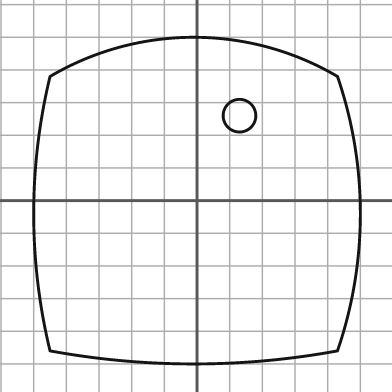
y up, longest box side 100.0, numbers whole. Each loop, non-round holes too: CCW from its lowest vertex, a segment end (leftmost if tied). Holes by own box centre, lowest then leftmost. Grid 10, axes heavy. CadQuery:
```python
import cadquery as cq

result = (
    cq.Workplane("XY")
    .moveTo(-45.0, -46.0)
    .threePointArc((-1.0, -50.0), (43.0, -46.0))
    .threePointArc((50.0, -4.0), (43.0, 38.0))
    .threePointArc((-1.0, 50.0), (-45.0, 38.0))
    .threePointArc((-50.0, -4.0), (-45.0, -46.0))
    .close()
    .moveTo(13.0, 26.0)
    .circle(5.0)
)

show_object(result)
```